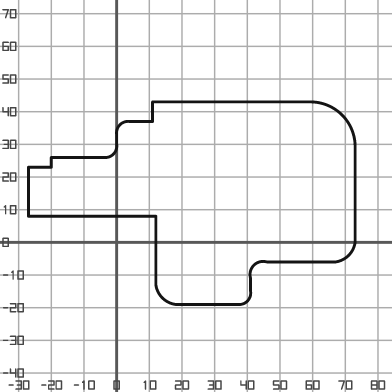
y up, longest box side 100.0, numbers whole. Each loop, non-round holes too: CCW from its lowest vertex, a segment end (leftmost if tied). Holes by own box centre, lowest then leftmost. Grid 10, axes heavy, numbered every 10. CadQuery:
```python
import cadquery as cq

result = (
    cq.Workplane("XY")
    .moveTo(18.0, -19.0)
    .lineTo(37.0, -19.0)
    .threePointArc((40.0, -18.0), (41.0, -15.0))
    .lineTo(41.0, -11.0)
    .threePointArc((42.0, -7.0), (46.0, -6.0))
    .lineTo(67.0, -6.0)
    .threePointArc((71.0, -4.0), (73.0, 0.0))
    .lineTo(73.0, 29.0)
    .threePointArc((69.0, 39.0), (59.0, 43.0))
    .lineTo(11.0, 43.0)
    .lineTo(11.0, 37.0)
    .lineTo(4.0, 37.0)
    .threePointArc((1.0, 36.0), (0.0, 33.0))
    .lineTo(0.0, 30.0)
    .threePointArc((-1.0, 27.0), (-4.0, 26.0))
    .lineTo(-20.0, 26.0)
    .lineTo(-20.0, 23.0)
    .lineTo(-27.0, 23.0)
    .lineTo(-27.0, 8.0)
    .lineTo(12.0, 8.0)
    .lineTo(12.0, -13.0)
    .threePointArc((14.0, -17.0), (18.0, -19.0))
    .close()
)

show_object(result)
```